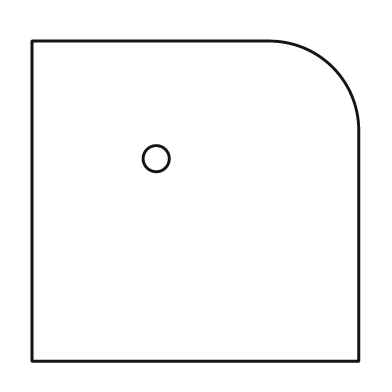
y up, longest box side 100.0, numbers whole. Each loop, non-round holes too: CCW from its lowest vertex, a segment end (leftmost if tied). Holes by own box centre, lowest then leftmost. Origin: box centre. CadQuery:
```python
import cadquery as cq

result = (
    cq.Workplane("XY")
    .moveTo(-50.0, -49.0)
    .lineTo(50.0, -49.0)
    .lineTo(50.0, 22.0)
    .threePointArc((42.0, 41.0), (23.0, 49.0))
    .lineTo(-50.0, 49.0)
    .close()
    .moveTo(-12.0, 13.0)
    .circle(4.0)
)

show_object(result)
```